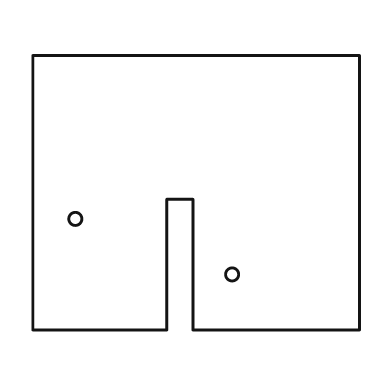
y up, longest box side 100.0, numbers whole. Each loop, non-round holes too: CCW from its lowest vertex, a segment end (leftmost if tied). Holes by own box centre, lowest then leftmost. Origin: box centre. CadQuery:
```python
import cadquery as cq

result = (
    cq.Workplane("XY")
    .moveTo(-50.0, -42.0)
    .lineTo(-9.0, -42.0)
    .lineTo(-9.0, -2.0)
    .lineTo(-1.0, -2.0)
    .lineTo(-1.0, -42.0)
    .lineTo(50.0, -42.0)
    .lineTo(50.0, 42.0)
    .lineTo(-50.0, 42.0)
    .close()
    .moveTo(11.0, -25.0)
    .circle(2.0)
    .moveTo(-37.0, -8.0)
    .circle(2.0)
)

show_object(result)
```